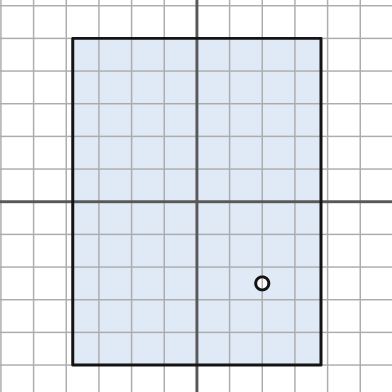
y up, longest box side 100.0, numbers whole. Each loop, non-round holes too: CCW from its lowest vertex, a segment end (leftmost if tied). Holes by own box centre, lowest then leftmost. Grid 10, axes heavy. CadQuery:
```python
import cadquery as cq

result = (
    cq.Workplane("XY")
    .moveTo(-38.0, -50.0)
    .lineTo(38.0, -50.0)
    .lineTo(38.0, 50.0)
    .lineTo(-38.0, 50.0)
    .close()
    .moveTo(20.0, -25.0)
    .circle(2.0)
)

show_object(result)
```